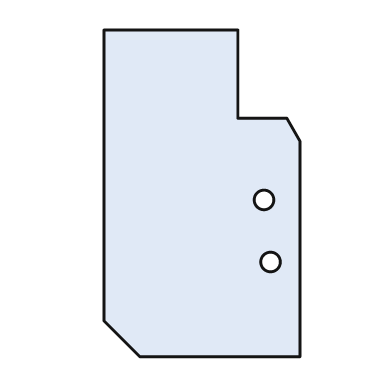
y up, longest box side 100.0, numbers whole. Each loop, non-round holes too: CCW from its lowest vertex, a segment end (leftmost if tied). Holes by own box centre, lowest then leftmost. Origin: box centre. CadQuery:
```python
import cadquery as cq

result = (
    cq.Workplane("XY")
    .moveTo(-19.0, -50.0)
    .lineTo(30.0, -50.0)
    .lineTo(30.0, 16.0)
    .lineTo(26.0, 23.0)
    .lineTo(11.0, 23.0)
    .lineTo(11.0, 50.0)
    .lineTo(-30.0, 50.0)
    .lineTo(-30.0, -39.0)
    .close()
    .moveTo(21.0, -21.0)
    .circle(3.0)
    .moveTo(19.0, -2.0)
    .circle(3.0)
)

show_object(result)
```